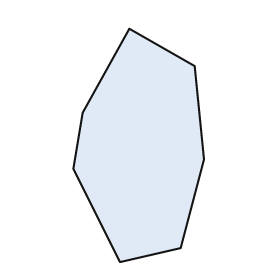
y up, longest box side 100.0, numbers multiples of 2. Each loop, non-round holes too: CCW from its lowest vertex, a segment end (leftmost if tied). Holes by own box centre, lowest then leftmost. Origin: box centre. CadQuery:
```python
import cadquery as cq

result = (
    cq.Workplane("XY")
    .moveTo(-8.0, -50.0)
    .lineTo(18.0, -44.0)
    .lineTo(28.0, -6.0)
    .lineTo(24.0, 34.0)
    .lineTo(-4.0, 50.0)
    .lineTo(-24.0, 14.0)
    .lineTo(-28.0, -10.0)
    .close()
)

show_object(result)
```